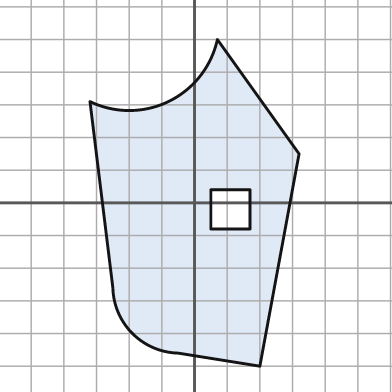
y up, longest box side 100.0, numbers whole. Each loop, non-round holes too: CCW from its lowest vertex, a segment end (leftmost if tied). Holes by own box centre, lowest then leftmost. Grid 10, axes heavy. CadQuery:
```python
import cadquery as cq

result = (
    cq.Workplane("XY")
    .moveTo(20.0, -50.0)
    .lineTo(32.0, 15.0)
    .lineTo(7.0, 50.0)
    .threePointArc((-8.0, 31.0), (-32.0, 31.0))
    .lineTo(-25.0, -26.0)
    .threePointArc((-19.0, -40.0), (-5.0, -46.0))
    .close()
    .moveTo(5.0, -8.0)
    .lineTo(17.0, -8.0)
    .lineTo(17.0, 4.0)
    .lineTo(5.0, 4.0)
    .close()
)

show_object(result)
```